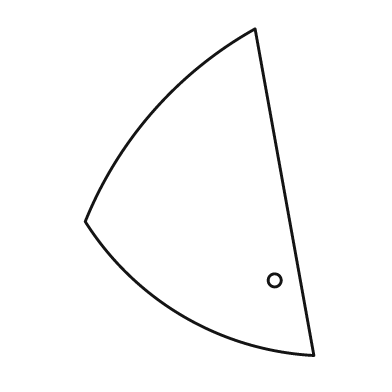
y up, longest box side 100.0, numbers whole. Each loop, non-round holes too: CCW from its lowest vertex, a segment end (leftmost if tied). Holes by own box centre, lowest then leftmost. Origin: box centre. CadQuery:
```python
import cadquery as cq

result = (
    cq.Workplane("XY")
    .moveTo(35.0, -50.0)
    .lineTo(17.0, 50.0)
    .threePointArc((-14.0, 25.0), (-35.0, -9.0))
    .threePointArc((-5.0, -38.0), (35.0, -50.0))
    .close()
    .moveTo(23.0, -27.0)
    .circle(2.0)
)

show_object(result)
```